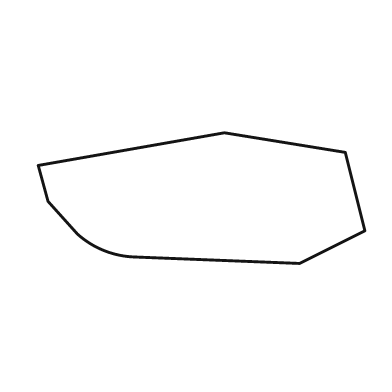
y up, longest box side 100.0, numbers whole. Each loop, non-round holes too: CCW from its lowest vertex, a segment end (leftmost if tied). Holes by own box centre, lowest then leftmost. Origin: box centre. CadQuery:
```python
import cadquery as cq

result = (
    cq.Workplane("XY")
    .moveTo(30.0, -20.0)
    .lineTo(50.0, -10.0)
    .lineTo(44.0, 14.0)
    .lineTo(7.0, 20.0)
    .lineTo(-50.0, 10.0)
    .lineTo(-47.0, -1.0)
    .lineTo(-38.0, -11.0)
    .threePointArc((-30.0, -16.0), (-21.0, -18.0))
    .close()
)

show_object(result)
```